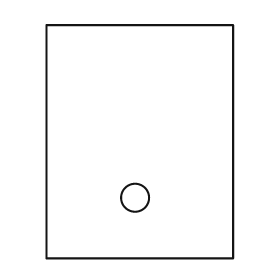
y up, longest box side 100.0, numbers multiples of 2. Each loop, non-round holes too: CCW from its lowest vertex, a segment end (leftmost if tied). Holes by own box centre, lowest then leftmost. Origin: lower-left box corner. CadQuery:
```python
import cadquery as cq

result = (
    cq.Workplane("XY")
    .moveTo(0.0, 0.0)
    .lineTo(80.0, 0.0)
    .lineTo(80.0, 100.0)
    .lineTo(0.0, 100.0)
    .close()
    .moveTo(38.0, 26.0)
    .circle(6.0)
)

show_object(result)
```